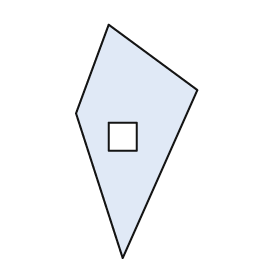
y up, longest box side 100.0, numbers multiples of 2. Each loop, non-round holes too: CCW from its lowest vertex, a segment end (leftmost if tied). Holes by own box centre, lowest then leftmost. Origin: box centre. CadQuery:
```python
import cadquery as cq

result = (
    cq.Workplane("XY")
    .moveTo(-6.0, -50.0)
    .lineTo(26.0, 22.0)
    .lineTo(-12.0, 50.0)
    .lineTo(-26.0, 12.0)
    .close()
    .moveTo(-12.0, -4.0)
    .lineTo(0.0, -4.0)
    .lineTo(0.0, 8.0)
    .lineTo(-12.0, 8.0)
    .close()
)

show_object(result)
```